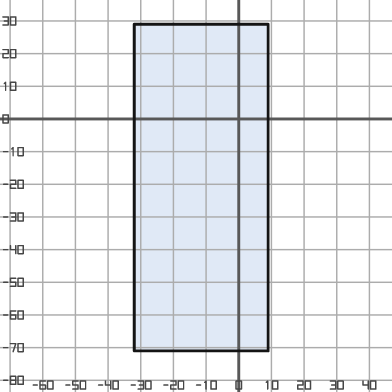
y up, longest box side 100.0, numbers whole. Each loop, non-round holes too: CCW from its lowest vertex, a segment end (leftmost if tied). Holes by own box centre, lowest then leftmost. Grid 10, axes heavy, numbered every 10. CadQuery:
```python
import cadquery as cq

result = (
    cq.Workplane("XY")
    .moveTo(-32.0, -71.0)
    .lineTo(9.0, -71.0)
    .lineTo(9.0, 29.0)
    .lineTo(-32.0, 29.0)
    .close()
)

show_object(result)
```